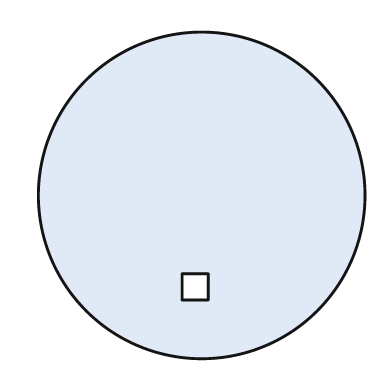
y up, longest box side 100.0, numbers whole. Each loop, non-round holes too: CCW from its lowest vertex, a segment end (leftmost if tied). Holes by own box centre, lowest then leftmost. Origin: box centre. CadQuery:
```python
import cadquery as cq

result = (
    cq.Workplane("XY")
    .moveTo(0.0, 0.0)
    .circle(50.0)
    .moveTo(-6.0, -32.0)
    .lineTo(2.0, -32.0)
    .lineTo(2.0, -24.0)
    .lineTo(-6.0, -24.0)
    .close()
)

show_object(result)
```